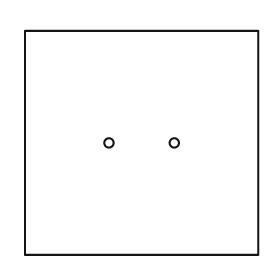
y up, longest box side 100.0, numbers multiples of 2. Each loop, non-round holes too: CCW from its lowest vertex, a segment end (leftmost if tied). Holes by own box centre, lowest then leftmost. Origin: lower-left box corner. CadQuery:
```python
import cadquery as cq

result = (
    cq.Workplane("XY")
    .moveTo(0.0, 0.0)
    .lineTo(100.0, 0.0)
    .lineTo(100.0, 96.0)
    .lineTo(0.0, 96.0)
    .close()
    .moveTo(36.0, 48.0)
    .circle(2.0)
    .moveTo(64.0, 48.0)
    .circle(2.0)
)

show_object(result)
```